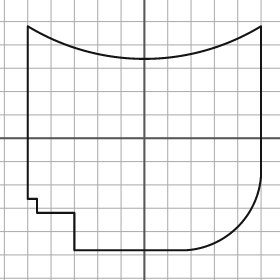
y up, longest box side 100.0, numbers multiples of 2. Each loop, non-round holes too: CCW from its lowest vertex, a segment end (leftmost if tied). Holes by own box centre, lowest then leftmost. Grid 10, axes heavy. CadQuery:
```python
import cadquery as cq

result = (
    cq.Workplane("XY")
    .moveTo(-30.0, -48.0)
    .lineTo(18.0, -48.0)
    .threePointArc((40.0, -38.0), (50.0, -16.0))
    .lineTo(50.0, 48.0)
    .threePointArc((0.0, 34.0), (-50.0, 48.0))
    .lineTo(-50.0, -26.0)
    .lineTo(-46.0, -26.0)
    .lineTo(-46.0, -32.0)
    .lineTo(-30.0, -32.0)
    .close()
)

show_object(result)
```